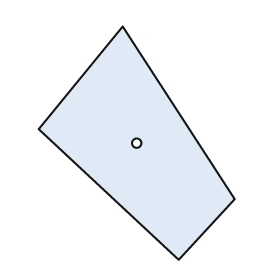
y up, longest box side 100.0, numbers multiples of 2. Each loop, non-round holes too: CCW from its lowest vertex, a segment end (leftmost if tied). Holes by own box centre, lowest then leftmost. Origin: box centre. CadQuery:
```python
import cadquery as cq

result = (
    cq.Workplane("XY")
    .moveTo(18.0, -50.0)
    .lineTo(42.0, -24.0)
    .lineTo(-6.0, 50.0)
    .lineTo(-42.0, 6.0)
    .close()
    .moveTo(0.0, 0.0)
    .circle(2.0)
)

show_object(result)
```